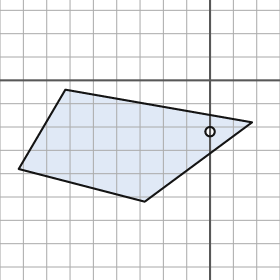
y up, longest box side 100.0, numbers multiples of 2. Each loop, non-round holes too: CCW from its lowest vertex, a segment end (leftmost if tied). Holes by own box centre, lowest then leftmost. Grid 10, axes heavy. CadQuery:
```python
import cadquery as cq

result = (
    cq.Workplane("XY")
    .moveTo(-28.0, -52.0)
    .lineTo(18.0, -18.0)
    .lineTo(-62.0, -4.0)
    .lineTo(-82.0, -38.0)
    .close()
    .moveTo(0.0, -22.0)
    .circle(2.0)
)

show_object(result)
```